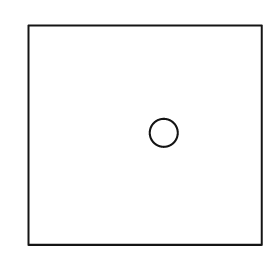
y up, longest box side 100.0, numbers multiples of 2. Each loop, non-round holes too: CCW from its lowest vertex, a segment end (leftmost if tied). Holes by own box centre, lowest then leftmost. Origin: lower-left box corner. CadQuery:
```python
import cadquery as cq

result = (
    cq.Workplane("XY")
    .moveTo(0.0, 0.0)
    .lineTo(100.0, 0.0)
    .lineTo(100.0, 94.0)
    .lineTo(0.0, 94.0)
    .close()
    .moveTo(58.0, 48.0)
    .circle(6.0)
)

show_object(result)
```